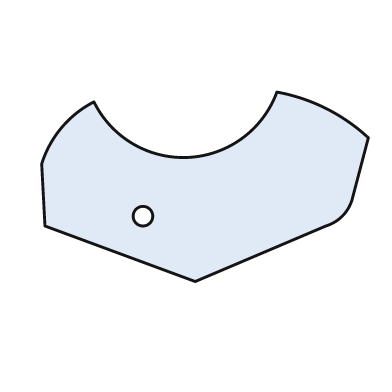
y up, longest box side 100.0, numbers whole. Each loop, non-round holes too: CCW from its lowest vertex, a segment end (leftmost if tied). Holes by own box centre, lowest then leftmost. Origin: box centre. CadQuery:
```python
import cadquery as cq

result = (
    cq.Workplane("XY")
    .moveTo(-3.0, -29.0)
    .lineTo(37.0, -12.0)
    .threePointArc((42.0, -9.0), (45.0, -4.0))
    .lineTo(50.0, 15.0)
    .threePointArc((37.0, 24.0), (22.0, 29.0))
    .threePointArc((-5.0, 9.0), (-34.0, 26.0))
    .threePointArc((-44.0, 18.0), (-50.0, 7.0))
    .lineTo(-49.0, -12.0)
    .close()
    .moveTo(-19.0, -9.0)
    .circle(3.0)
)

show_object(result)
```